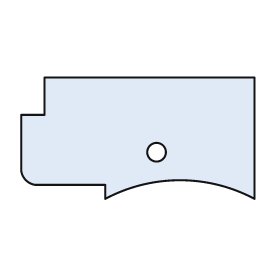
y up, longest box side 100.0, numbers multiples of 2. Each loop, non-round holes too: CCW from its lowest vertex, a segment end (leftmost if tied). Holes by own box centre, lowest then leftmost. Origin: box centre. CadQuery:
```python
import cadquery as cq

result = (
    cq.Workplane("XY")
    .moveTo(-14.0, -26.0)
    .threePointArc((18.0, -18.0), (50.0, -26.0))
    .lineTo(50.0, 26.0)
    .lineTo(-40.0, 26.0)
    .lineTo(-40.0, 10.0)
    .lineTo(-50.0, 10.0)
    .lineTo(-50.0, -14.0)
    .threePointArc((-48.0, -18.0), (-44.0, -20.0))
    .lineTo(-14.0, -20.0)
    .close()
    .moveTo(8.0, -6.0)
    .circle(4.0)
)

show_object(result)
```